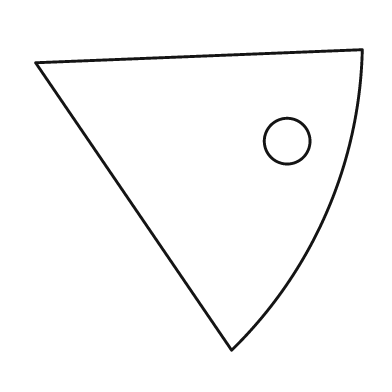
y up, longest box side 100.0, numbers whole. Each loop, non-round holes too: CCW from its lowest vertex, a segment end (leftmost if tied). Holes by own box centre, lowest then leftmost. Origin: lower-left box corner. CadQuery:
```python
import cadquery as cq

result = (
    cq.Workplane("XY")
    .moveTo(60.0, 0.0)
    .threePointArc((89.0, 42.0), (100.0, 92.0))
    .lineTo(0.0, 88.0)
    .close()
    .moveTo(77.0, 64.0)
    .circle(7.0)
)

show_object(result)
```